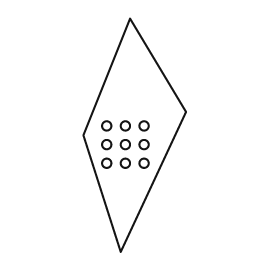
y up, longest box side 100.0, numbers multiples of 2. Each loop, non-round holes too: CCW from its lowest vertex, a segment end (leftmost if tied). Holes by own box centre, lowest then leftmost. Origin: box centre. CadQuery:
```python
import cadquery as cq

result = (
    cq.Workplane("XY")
    .moveTo(-6.0, -50.0)
    .lineTo(22.0, 10.0)
    .lineTo(-2.0, 50.0)
    .lineTo(-22.0, 0.0)
    .close()
    .moveTo(-12.0, -12.0)
    .circle(2.0)
    .moveTo(-4.0, -12.0)
    .circle(2.0)
    .moveTo(4.0, -12.0)
    .circle(2.0)
    .moveTo(-12.0, -4.0)
    .circle(2.0)
    .moveTo(-4.0, -4.0)
    .circle(2.0)
    .moveTo(4.0, -4.0)
    .circle(2.0)
    .moveTo(-12.0, 4.0)
    .circle(2.0)
    .moveTo(-4.0, 4.0)
    .circle(2.0)
    .moveTo(4.0, 4.0)
    .circle(2.0)
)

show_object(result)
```